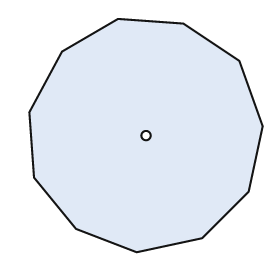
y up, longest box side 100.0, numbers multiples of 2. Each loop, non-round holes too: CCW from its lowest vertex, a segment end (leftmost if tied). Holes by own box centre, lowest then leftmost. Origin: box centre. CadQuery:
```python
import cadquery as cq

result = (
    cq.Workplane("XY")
    .moveTo(-4.0, -50.0)
    .lineTo(24.0, -44.0)
    .lineTo(44.0, -24.0)
    .lineTo(50.0, 4.0)
    .lineTo(40.0, 32.0)
    .lineTo(16.0, 48.0)
    .lineTo(-12.0, 50.0)
    .lineTo(-36.0, 36.0)
    .lineTo(-50.0, 10.0)
    .lineTo(-48.0, -18.0)
    .lineTo(-30.0, -40.0)
    .close()
    .moveTo(0.0, 0.0)
    .circle(2.0)
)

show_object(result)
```